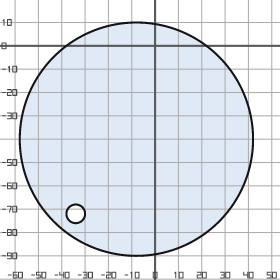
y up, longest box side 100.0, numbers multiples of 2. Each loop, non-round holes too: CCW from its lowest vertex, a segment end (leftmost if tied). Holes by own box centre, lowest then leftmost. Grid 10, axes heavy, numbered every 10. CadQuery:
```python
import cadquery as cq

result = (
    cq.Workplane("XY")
    .moveTo(-8.0, -40.0)
    .circle(50.0)
    .moveTo(-34.0, -72.0)
    .circle(4.0)
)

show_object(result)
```